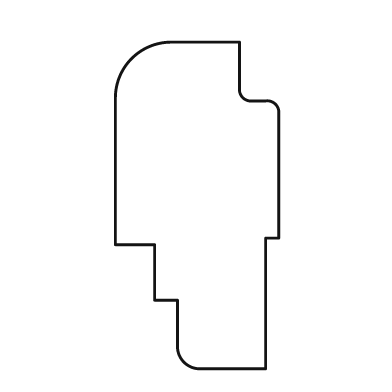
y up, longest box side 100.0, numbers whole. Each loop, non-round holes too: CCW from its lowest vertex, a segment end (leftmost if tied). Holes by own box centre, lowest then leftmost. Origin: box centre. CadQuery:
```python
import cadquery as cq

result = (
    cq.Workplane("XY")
    .moveTo(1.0, -50.0)
    .lineTo(21.0, -50.0)
    .lineTo(21.0, -10.0)
    .lineTo(25.0, -10.0)
    .lineTo(25.0, 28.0)
    .threePointArc((24.0, 31.0), (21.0, 32.0))
    .lineTo(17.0, 32.0)
    .threePointArc((14.0, 33.0), (13.0, 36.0))
    .lineTo(13.0, 50.0)
    .lineTo(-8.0, 50.0)
    .threePointArc((-20.0, 45.0), (-25.0, 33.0))
    .lineTo(-25.0, -12.0)
    .lineTo(-13.0, -12.0)
    .lineTo(-13.0, -29.0)
    .lineTo(-6.0, -29.0)
    .lineTo(-6.0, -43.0)
    .threePointArc((-4.0, -48.0), (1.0, -50.0))
    .close()
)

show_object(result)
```